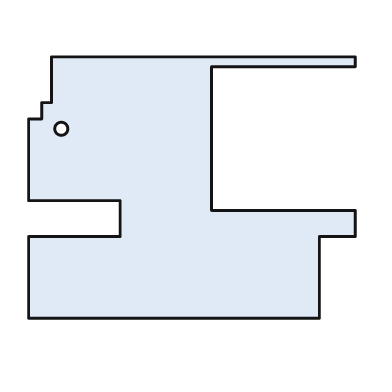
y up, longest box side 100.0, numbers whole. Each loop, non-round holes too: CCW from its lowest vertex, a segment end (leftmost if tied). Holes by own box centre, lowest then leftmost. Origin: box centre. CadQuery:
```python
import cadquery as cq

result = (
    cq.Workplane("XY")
    .moveTo(-50.0, -40.0)
    .lineTo(39.0, -40.0)
    .lineTo(39.0, -15.0)
    .lineTo(50.0, -15.0)
    .lineTo(50.0, -7.0)
    .lineTo(6.0, -7.0)
    .lineTo(6.0, 37.0)
    .lineTo(50.0, 37.0)
    .lineTo(50.0, 40.0)
    .lineTo(-43.0, 40.0)
    .lineTo(-43.0, 26.0)
    .lineTo(-46.0, 26.0)
    .lineTo(-46.0, 21.0)
    .lineTo(-50.0, 21.0)
    .lineTo(-50.0, -4.0)
    .lineTo(-22.0, -4.0)
    .lineTo(-22.0, -15.0)
    .lineTo(-50.0, -15.0)
    .close()
    .moveTo(-40.0, 18.0)
    .circle(2.0)
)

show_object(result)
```